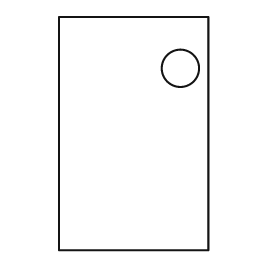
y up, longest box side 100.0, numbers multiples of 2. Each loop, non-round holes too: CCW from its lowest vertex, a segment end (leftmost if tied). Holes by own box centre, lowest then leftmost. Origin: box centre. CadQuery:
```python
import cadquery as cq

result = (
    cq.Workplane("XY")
    .moveTo(-32.0, -50.0)
    .lineTo(32.0, -50.0)
    .lineTo(32.0, 50.0)
    .lineTo(-32.0, 50.0)
    .close()
    .moveTo(20.0, 28.0)
    .circle(8.0)
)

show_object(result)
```